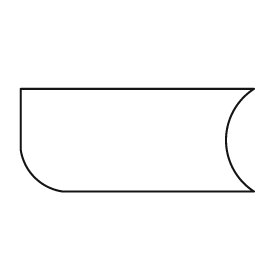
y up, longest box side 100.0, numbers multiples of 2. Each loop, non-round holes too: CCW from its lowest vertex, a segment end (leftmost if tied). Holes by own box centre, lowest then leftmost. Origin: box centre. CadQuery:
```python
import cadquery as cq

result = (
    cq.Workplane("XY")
    .moveTo(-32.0, -22.0)
    .lineTo(50.0, -22.0)
    .threePointArc((38.0, 0.0), (50.0, 22.0))
    .lineTo(-50.0, 22.0)
    .lineTo(-50.0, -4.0)
    .threePointArc((-44.0, -16.0), (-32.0, -22.0))
    .close()
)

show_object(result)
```